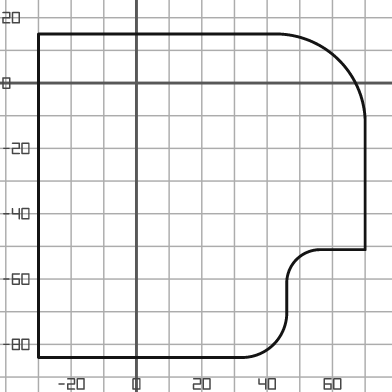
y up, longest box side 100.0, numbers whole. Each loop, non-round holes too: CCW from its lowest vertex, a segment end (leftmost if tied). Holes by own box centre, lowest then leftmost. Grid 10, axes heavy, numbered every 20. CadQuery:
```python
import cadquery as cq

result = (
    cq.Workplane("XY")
    .moveTo(-30.0, -84.0)
    .lineTo(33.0, -84.0)
    .threePointArc((42.0, -80.0), (46.0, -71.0))
    .lineTo(46.0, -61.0)
    .threePointArc((49.0, -54.0), (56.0, -51.0))
    .lineTo(70.0, -51.0)
    .lineTo(70.0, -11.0)
    .threePointArc((62.0, 7.0), (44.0, 15.0))
    .lineTo(-30.0, 15.0)
    .close()
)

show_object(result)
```